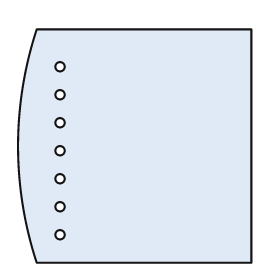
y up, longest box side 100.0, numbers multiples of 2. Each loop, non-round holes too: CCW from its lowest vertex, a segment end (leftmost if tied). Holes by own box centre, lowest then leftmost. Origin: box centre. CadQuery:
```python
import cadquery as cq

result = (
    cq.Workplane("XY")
    .moveTo(-42.0, -50.0)
    .lineTo(50.0, -50.0)
    .lineTo(50.0, 50.0)
    .lineTo(-42.0, 50.0)
    .threePointArc((-50.0, 0.0), (-42.0, -50.0))
    .close()
    .moveTo(-32.0, -38.0)
    .circle(2.0)
    .moveTo(-32.0, -26.0)
    .circle(2.0)
    .moveTo(-32.0, -14.0)
    .circle(2.0)
    .moveTo(-32.0, -2.0)
    .circle(2.0)
    .moveTo(-32.0, 10.0)
    .circle(2.0)
    .moveTo(-32.0, 22.0)
    .circle(2.0)
    .moveTo(-32.0, 34.0)
    .circle(2.0)
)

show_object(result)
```